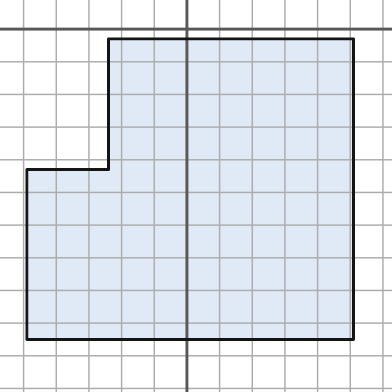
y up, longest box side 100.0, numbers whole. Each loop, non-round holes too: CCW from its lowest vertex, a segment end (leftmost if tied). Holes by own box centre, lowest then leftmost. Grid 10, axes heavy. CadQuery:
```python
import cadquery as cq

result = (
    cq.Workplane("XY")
    .moveTo(-49.0, -95.0)
    .lineTo(51.0, -95.0)
    .lineTo(51.0, -3.0)
    .lineTo(-24.0, -3.0)
    .lineTo(-24.0, -43.0)
    .lineTo(-49.0, -43.0)
    .close()
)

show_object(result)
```